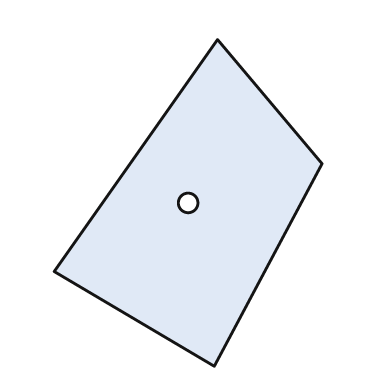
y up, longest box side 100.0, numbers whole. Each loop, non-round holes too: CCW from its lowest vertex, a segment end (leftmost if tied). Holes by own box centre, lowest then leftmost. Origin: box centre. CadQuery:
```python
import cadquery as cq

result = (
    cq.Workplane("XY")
    .moveTo(8.0, -50.0)
    .lineTo(41.0, 12.0)
    .lineTo(9.0, 50.0)
    .lineTo(-41.0, -21.0)
    .close()
    .moveTo(0.0, 0.0)
    .circle(3.0)
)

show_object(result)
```